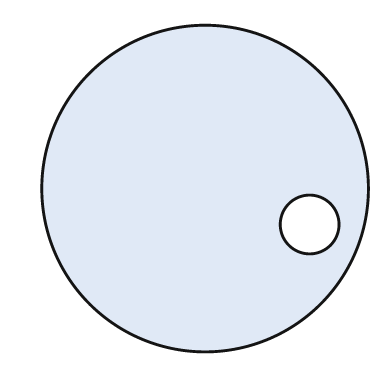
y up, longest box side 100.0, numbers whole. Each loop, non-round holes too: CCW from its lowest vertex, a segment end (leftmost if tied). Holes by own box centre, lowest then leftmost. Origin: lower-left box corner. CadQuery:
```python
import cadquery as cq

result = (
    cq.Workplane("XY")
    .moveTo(50.0, 50.0)
    .circle(50.0)
    .moveTo(82.0, 39.0)
    .circle(9.0)
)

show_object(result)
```